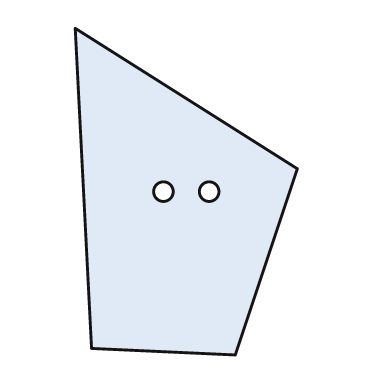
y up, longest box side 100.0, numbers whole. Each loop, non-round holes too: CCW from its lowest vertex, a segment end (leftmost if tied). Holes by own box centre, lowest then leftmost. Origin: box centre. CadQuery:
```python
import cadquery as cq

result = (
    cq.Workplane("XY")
    .moveTo(15.0, -50.0)
    .lineTo(34.0, 7.0)
    .lineTo(-34.0, 50.0)
    .lineTo(-29.0, -48.0)
    .close()
    .moveTo(-7.0, 0.0)
    .circle(3.0)
    .moveTo(7.0, 0.0)
    .circle(3.0)
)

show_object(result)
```